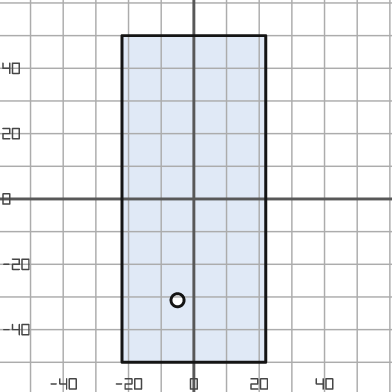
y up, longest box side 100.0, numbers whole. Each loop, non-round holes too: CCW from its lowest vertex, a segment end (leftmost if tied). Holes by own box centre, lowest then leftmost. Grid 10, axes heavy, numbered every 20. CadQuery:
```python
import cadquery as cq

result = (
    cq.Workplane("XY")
    .moveTo(-22.0, -50.0)
    .lineTo(22.0, -50.0)
    .lineTo(22.0, 50.0)
    .lineTo(-22.0, 50.0)
    .close()
    .moveTo(-5.0, -31.0)
    .circle(2.0)
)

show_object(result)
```